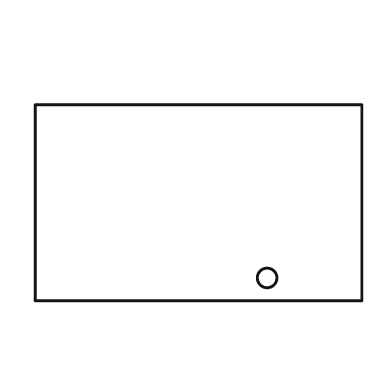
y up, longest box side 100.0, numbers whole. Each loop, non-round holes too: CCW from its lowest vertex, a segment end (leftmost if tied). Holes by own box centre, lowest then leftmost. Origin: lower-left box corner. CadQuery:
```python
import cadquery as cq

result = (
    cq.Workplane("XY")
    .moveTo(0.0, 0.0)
    .lineTo(100.0, 0.0)
    .lineTo(100.0, 60.0)
    .lineTo(0.0, 60.0)
    .close()
    .moveTo(71.0, 7.0)
    .circle(3.0)
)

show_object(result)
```